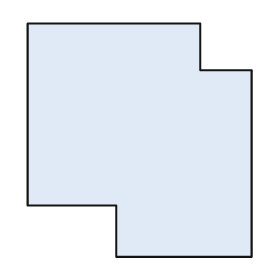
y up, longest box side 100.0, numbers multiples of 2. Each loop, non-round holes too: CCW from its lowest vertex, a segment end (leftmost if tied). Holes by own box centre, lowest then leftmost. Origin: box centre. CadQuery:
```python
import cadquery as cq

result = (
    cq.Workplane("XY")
    .moveTo(-10.0, -50.0)
    .lineTo(48.0, -50.0)
    .lineTo(48.0, 30.0)
    .lineTo(26.0, 30.0)
    .lineTo(26.0, 50.0)
    .lineTo(-48.0, 50.0)
    .lineTo(-48.0, -28.0)
    .lineTo(-10.0, -28.0)
    .close()
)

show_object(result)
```